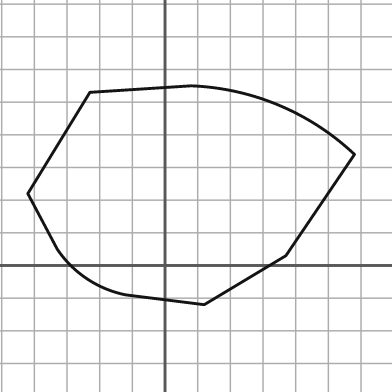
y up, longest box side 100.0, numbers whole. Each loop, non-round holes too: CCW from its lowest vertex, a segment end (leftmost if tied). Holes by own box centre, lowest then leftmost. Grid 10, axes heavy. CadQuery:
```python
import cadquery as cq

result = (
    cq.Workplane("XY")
    .moveTo(12.0, -12.0)
    .lineTo(37.0, 3.0)
    .lineTo(58.0, 34.0)
    .threePointArc((35.0, 49.0), (8.0, 55.0))
    .lineTo(-23.0, 53.0)
    .lineTo(-42.0, 22.0)
    .lineTo(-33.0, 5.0)
    .threePointArc((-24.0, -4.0), (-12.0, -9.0))
    .close()
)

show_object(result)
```